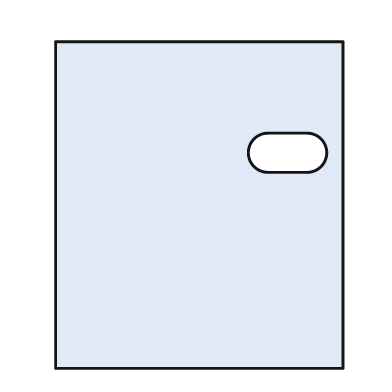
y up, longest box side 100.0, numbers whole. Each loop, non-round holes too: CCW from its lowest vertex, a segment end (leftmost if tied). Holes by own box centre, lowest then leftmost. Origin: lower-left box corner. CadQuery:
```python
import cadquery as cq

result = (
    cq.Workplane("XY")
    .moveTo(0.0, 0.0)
    .lineTo(88.0, 0.0)
    .lineTo(88.0, 100.0)
    .lineTo(0.0, 100.0)
    .close()
    .moveTo(65.0, 60.0)
    .lineTo(77.0, 60.0)
    .threePointArc((83.0, 66.0), (77.0, 72.0))
    .lineTo(65.0, 72.0)
    .threePointArc((59.0, 66.0), (65.0, 60.0))
    .close()
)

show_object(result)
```